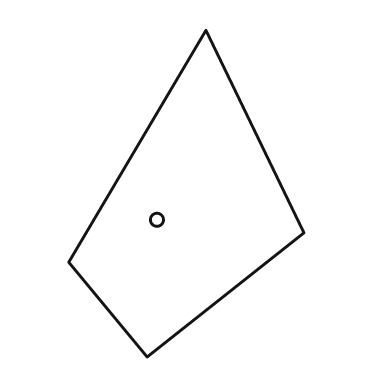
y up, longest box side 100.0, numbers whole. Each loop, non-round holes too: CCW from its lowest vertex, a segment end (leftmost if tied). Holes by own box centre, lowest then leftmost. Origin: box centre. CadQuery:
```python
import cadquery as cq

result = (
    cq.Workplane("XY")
    .moveTo(-12.0, -50.0)
    .lineTo(36.0, -12.0)
    .lineTo(6.0, 50.0)
    .lineTo(-36.0, -21.0)
    .close()
    .moveTo(-9.0, -8.0)
    .circle(2.0)
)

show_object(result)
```